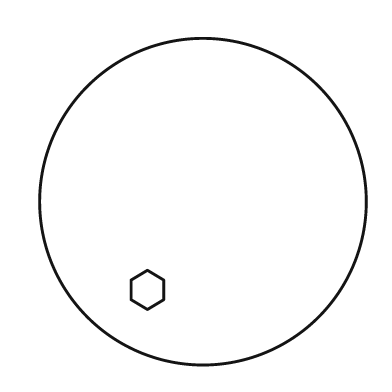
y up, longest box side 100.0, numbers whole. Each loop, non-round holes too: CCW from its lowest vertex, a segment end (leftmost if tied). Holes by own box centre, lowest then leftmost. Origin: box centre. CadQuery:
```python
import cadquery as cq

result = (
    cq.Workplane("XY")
    .moveTo(0.0, 0.0)
    .circle(50.0)
    .moveTo(-17.0, -33.0)
    .lineTo(-12.0, -30.0)
    .lineTo(-12.0, -24.0)
    .lineTo(-17.0, -21.0)
    .lineTo(-22.0, -24.0)
    .lineTo(-22.0, -30.0)
    .close()
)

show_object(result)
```